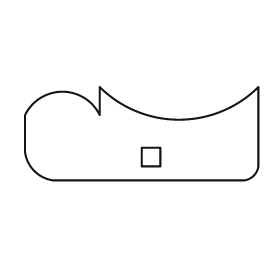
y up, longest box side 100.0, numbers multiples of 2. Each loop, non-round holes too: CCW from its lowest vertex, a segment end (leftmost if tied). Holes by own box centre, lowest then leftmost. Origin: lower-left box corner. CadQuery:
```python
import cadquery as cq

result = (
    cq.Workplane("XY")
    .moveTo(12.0, 0.0)
    .lineTo(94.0, 0.0)
    .threePointArc((98.0, 2.0), (100.0, 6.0))
    .lineTo(100.0, 40.0)
    .threePointArc((66.0, 26.0), (32.0, 40.0))
    .lineTo(32.0, 28.0)
    .threePointArc((16.0, 38.0), (0.0, 28.0))
    .lineTo(0.0, 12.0)
    .threePointArc((4.0, 4.0), (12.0, 0.0))
    .close()
    .moveTo(50.0, 6.0)
    .lineTo(58.0, 6.0)
    .lineTo(58.0, 14.0)
    .lineTo(50.0, 14.0)
    .close()
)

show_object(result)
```